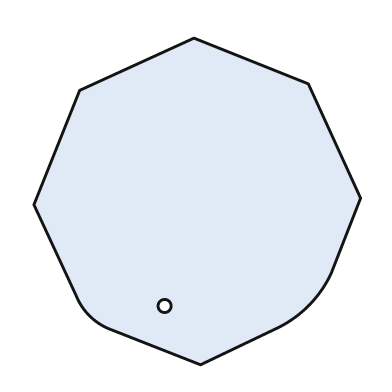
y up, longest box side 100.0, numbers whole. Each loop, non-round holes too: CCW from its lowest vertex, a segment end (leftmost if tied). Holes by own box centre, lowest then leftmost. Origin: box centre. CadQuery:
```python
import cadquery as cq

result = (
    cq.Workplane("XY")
    .moveTo(1.0, -50.0)
    .lineTo(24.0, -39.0)
    .threePointArc((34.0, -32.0), (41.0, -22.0))
    .lineTo(50.0, 1.0)
    .lineTo(34.0, 36.0)
    .lineTo(-1.0, 50.0)
    .lineTo(-36.0, 34.0)
    .lineTo(-50.0, -1.0)
    .lineTo(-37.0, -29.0)
    .threePointArc((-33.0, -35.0), (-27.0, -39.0))
    .close()
    .moveTo(-10.0, -32.0)
    .circle(2.0)
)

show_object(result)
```